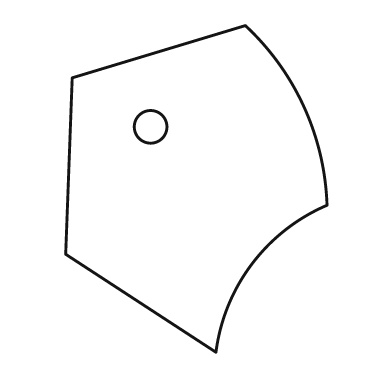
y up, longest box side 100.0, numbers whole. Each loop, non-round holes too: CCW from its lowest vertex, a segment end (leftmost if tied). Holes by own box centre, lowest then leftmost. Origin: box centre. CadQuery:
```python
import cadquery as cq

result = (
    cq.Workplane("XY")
    .moveTo(6.0, -50.0)
    .threePointArc((17.0, -23.0), (40.0, -5.0))
    .threePointArc((33.0, 25.0), (15.0, 50.0))
    .lineTo(-38.0, 34.0)
    .lineTo(-40.0, -20.0)
    .close()
    .moveTo(-14.0, 19.0)
    .circle(5.0)
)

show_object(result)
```